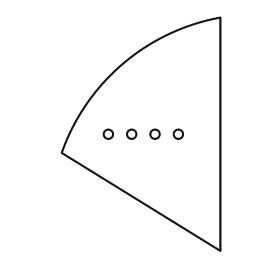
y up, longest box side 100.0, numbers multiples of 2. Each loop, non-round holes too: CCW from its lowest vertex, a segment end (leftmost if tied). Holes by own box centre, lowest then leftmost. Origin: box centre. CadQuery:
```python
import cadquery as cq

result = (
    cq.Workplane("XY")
    .moveTo(34.0, -50.0)
    .lineTo(34.0, 50.0)
    .threePointArc((-8.0, 30.0), (-34.0, -8.0))
    .close()
    .moveTo(-14.0, 0.0)
    .circle(2.0)
    .moveTo(-4.0, 0.0)
    .circle(2.0)
    .moveTo(6.0, 0.0)
    .circle(2.0)
    .moveTo(16.0, 0.0)
    .circle(2.0)
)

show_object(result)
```